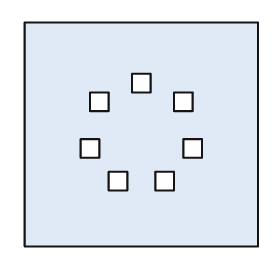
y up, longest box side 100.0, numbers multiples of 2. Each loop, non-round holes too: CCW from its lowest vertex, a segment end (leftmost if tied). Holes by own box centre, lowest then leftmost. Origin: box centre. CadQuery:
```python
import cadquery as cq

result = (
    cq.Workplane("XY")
    .moveTo(-50.0, -48.0)
    .lineTo(50.0, -48.0)
    .lineTo(50.0, 48.0)
    .lineTo(-50.0, 48.0)
    .close()
    .moveTo(-14.0, -24.0)
    .lineTo(-6.0, -24.0)
    .lineTo(-6.0, -16.0)
    .lineTo(-14.0, -16.0)
    .close()
    .moveTo(6.0, -24.0)
    .lineTo(14.0, -24.0)
    .lineTo(14.0, -16.0)
    .lineTo(6.0, -16.0)
    .close()
    .moveTo(-26.0, -10.0)
    .lineTo(-18.0, -10.0)
    .lineTo(-18.0, -2.0)
    .lineTo(-26.0, -2.0)
    .close()
    .moveTo(18.0, -10.0)
    .lineTo(26.0, -10.0)
    .lineTo(26.0, -2.0)
    .lineTo(18.0, -2.0)
    .close()
    .moveTo(-22.0, 10.0)
    .lineTo(-14.0, 10.0)
    .lineTo(-14.0, 18.0)
    .lineTo(-22.0, 18.0)
    .close()
    .moveTo(14.0, 10.0)
    .lineTo(22.0, 10.0)
    .lineTo(22.0, 18.0)
    .lineTo(14.0, 18.0)
    .close()
    .moveTo(-4.0, 18.0)
    .lineTo(4.0, 18.0)
    .lineTo(4.0, 26.0)
    .lineTo(-4.0, 26.0)
    .close()
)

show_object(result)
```